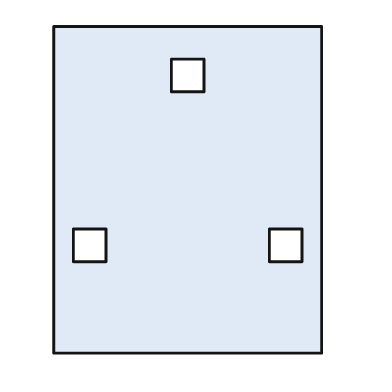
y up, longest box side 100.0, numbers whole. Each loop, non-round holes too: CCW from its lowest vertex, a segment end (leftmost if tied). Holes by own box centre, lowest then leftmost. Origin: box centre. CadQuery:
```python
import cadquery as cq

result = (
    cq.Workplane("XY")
    .moveTo(-41.0, -50.0)
    .lineTo(41.0, -50.0)
    .lineTo(41.0, 50.0)
    .lineTo(-41.0, 50.0)
    .close()
    .moveTo(-35.0, -22.0)
    .lineTo(-25.0, -22.0)
    .lineTo(-25.0, -12.0)
    .lineTo(-35.0, -12.0)
    .close()
    .moveTo(25.0, -22.0)
    .lineTo(35.0, -22.0)
    .lineTo(35.0, -12.0)
    .lineTo(25.0, -12.0)
    .close()
    .moveTo(-5.0, 30.0)
    .lineTo(5.0, 30.0)
    .lineTo(5.0, 40.0)
    .lineTo(-5.0, 40.0)
    .close()
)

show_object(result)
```